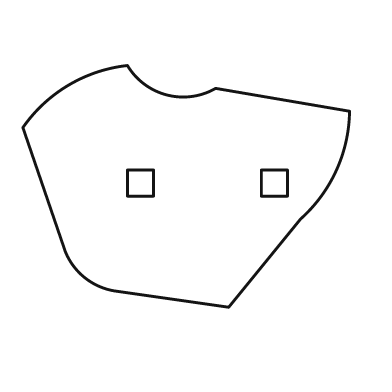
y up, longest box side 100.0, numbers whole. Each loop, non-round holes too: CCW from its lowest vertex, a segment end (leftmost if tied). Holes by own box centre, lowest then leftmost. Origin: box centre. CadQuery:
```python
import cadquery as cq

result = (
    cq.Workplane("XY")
    .moveTo(13.0, -37.0)
    .lineTo(35.0, -10.0)
    .threePointArc((46.0, 5.0), (50.0, 23.0))
    .lineTo(9.0, 30.0)
    .threePointArc((-6.0, 28.0), (-18.0, 37.0))
    .threePointArc((-36.0, 31.0), (-50.0, 18.0))
    .lineTo(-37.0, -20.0)
    .threePointArc((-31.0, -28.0), (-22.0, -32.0))
    .close()
    .moveTo(-18.0, -3.0)
    .lineTo(-10.0, -3.0)
    .lineTo(-10.0, 5.0)
    .lineTo(-18.0, 5.0)
    .close()
    .moveTo(23.0, -3.0)
    .lineTo(31.0, -3.0)
    .lineTo(31.0, 5.0)
    .lineTo(23.0, 5.0)
    .close()
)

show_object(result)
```